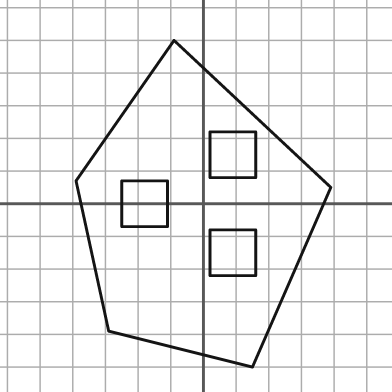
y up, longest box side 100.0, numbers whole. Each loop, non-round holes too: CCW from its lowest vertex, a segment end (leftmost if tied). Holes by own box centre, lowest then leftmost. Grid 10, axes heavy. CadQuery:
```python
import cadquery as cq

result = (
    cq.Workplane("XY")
    .moveTo(15.0, -50.0)
    .lineTo(39.0, 5.0)
    .lineTo(-9.0, 50.0)
    .lineTo(-39.0, 7.0)
    .lineTo(-29.0, -39.0)
    .close()
    .moveTo(2.0, -22.0)
    .lineTo(16.0, -22.0)
    .lineTo(16.0, -8.0)
    .lineTo(2.0, -8.0)
    .close()
    .moveTo(-25.0, -7.0)
    .lineTo(-11.0, -7.0)
    .lineTo(-11.0, 7.0)
    .lineTo(-25.0, 7.0)
    .close()
    .moveTo(2.0, 8.0)
    .lineTo(16.0, 8.0)
    .lineTo(16.0, 22.0)
    .lineTo(2.0, 22.0)
    .close()
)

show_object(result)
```